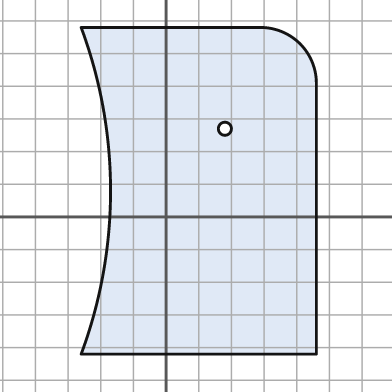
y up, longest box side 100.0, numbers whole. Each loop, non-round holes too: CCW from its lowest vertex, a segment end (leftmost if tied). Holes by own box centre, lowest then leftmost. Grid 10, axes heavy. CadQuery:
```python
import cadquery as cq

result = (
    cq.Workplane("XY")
    .moveTo(-26.0, -42.0)
    .lineTo(46.0, -42.0)
    .lineTo(46.0, 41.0)
    .threePointArc((41.0, 53.0), (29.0, 58.0))
    .lineTo(-26.0, 58.0)
    .threePointArc((-17.0, 8.0), (-26.0, -42.0))
    .close()
    .moveTo(18.0, 27.0)
    .circle(2.0)
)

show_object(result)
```